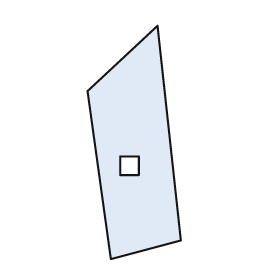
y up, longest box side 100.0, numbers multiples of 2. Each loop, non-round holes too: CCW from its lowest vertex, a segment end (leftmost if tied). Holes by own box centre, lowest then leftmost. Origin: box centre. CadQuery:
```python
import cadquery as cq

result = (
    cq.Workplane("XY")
    .moveTo(-10.0, -50.0)
    .lineTo(20.0, -42.0)
    .lineTo(10.0, 50.0)
    .lineTo(-20.0, 22.0)
    .close()
    .moveTo(-6.0, -14.0)
    .lineTo(2.0, -14.0)
    .lineTo(2.0, -6.0)
    .lineTo(-6.0, -6.0)
    .close()
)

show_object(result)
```